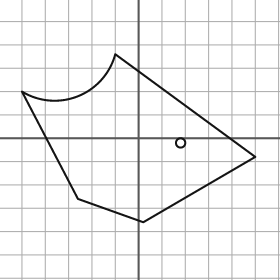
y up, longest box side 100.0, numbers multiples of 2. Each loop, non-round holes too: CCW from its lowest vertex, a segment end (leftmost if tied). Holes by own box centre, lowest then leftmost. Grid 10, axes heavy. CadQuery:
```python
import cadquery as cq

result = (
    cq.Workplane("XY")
    .moveTo(2.0, -36.0)
    .lineTo(50.0, -8.0)
    .lineTo(-10.0, 36.0)
    .threePointArc((-26.0, 18.0), (-50.0, 20.0))
    .lineTo(-26.0, -26.0)
    .close()
    .moveTo(18.0, -2.0)
    .circle(2.0)
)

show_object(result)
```